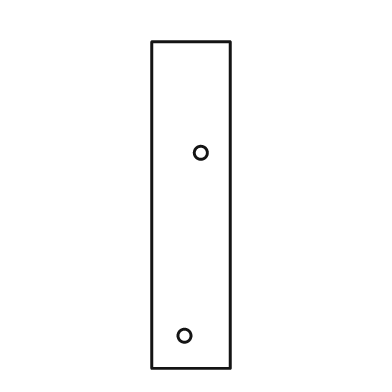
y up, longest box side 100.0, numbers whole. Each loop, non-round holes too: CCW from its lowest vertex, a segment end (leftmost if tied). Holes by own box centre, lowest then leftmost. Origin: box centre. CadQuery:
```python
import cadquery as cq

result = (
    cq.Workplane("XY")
    .moveTo(-12.0, -50.0)
    .lineTo(12.0, -50.0)
    .lineTo(12.0, 50.0)
    .lineTo(-12.0, 50.0)
    .close()
    .moveTo(-2.0, -40.0)
    .circle(2.0)
    .moveTo(3.0, 16.0)
    .circle(2.0)
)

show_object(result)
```